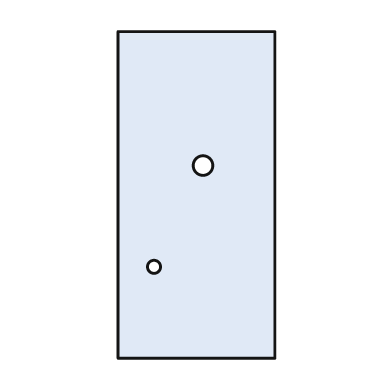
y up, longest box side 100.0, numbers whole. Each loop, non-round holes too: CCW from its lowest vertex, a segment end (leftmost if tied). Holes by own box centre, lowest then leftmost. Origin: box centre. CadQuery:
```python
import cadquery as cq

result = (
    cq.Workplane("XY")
    .moveTo(-24.0, -50.0)
    .lineTo(24.0, -50.0)
    .lineTo(24.0, 50.0)
    .lineTo(-24.0, 50.0)
    .close()
    .moveTo(-13.0, -22.0)
    .circle(2.0)
    .moveTo(2.0, 9.0)
    .circle(3.0)
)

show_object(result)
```